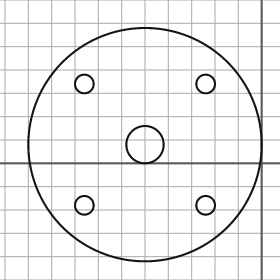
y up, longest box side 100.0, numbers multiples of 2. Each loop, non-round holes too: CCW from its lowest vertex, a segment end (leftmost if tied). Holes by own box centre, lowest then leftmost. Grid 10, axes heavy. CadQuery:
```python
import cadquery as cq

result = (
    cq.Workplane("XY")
    .moveTo(-50.0, 8.0)
    .circle(50.0)
    .moveTo(-76.0, -18.0)
    .circle(4.0)
    .moveTo(-24.0, -18.0)
    .circle(4.0)
    .moveTo(-50.0, 8.0)
    .circle(8.0)
    .moveTo(-76.0, 34.0)
    .circle(4.0)
    .moveTo(-24.0, 34.0)
    .circle(4.0)
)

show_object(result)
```